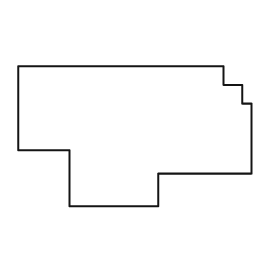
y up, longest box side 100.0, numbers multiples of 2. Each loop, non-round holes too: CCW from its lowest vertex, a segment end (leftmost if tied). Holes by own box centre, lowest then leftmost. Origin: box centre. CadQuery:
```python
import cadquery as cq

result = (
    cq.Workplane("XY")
    .moveTo(-28.0, -30.0)
    .lineTo(10.0, -30.0)
    .lineTo(10.0, -16.0)
    .lineTo(50.0, -16.0)
    .lineTo(50.0, 14.0)
    .lineTo(46.0, 14.0)
    .lineTo(46.0, 22.0)
    .lineTo(38.0, 22.0)
    .lineTo(38.0, 30.0)
    .lineTo(-50.0, 30.0)
    .lineTo(-50.0, -6.0)
    .lineTo(-28.0, -6.0)
    .close()
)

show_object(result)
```